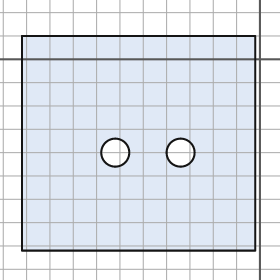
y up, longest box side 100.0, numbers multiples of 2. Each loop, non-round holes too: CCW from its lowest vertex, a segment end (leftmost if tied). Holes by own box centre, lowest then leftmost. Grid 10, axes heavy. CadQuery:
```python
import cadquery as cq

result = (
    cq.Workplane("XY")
    .moveTo(-102.0, -82.0)
    .lineTo(-2.0, -82.0)
    .lineTo(-2.0, 10.0)
    .lineTo(-102.0, 10.0)
    .close()
    .moveTo(-62.0, -40.0)
    .circle(6.0)
    .moveTo(-34.0, -40.0)
    .circle(6.0)
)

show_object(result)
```